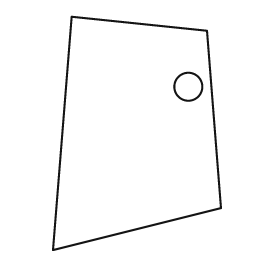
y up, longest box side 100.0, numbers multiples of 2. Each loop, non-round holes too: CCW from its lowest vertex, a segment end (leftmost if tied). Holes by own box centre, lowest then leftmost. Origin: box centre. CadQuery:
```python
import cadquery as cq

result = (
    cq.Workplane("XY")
    .moveTo(-36.0, -50.0)
    .lineTo(36.0, -32.0)
    .lineTo(30.0, 44.0)
    .lineTo(-28.0, 50.0)
    .close()
    .moveTo(22.0, 20.0)
    .circle(6.0)
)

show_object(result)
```